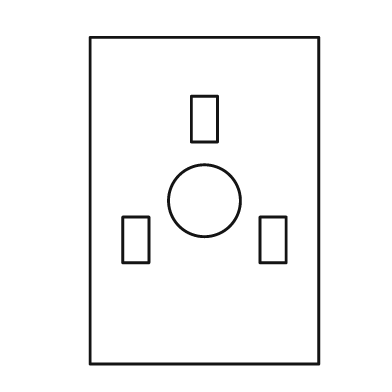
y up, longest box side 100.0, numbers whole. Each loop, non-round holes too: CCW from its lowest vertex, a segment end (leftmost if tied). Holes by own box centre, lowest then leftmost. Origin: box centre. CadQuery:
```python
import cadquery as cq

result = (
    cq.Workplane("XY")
    .moveTo(-35.0, -50.0)
    .lineTo(35.0, -50.0)
    .lineTo(35.0, 50.0)
    .lineTo(-35.0, 50.0)
    .close()
    .moveTo(-25.0, -19.0)
    .lineTo(-17.0, -19.0)
    .lineTo(-17.0, -5.0)
    .lineTo(-25.0, -5.0)
    .close()
    .moveTo(17.0, -19.0)
    .lineTo(25.0, -19.0)
    .lineTo(25.0, -5.0)
    .lineTo(17.0, -5.0)
    .close()
    .moveTo(0.0, 0.0)
    .circle(11.0)
    .moveTo(-4.0, 18.0)
    .lineTo(4.0, 18.0)
    .lineTo(4.0, 32.0)
    .lineTo(-4.0, 32.0)
    .close()
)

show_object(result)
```